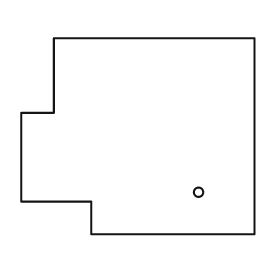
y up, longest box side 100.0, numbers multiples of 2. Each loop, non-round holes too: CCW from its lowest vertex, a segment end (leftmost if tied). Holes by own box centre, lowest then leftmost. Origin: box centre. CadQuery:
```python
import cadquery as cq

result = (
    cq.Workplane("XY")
    .moveTo(-20.0, -42.0)
    .lineTo(50.0, -42.0)
    .lineTo(50.0, 42.0)
    .lineTo(-36.0, 42.0)
    .lineTo(-36.0, 10.0)
    .lineTo(-50.0, 10.0)
    .lineTo(-50.0, -28.0)
    .lineTo(-20.0, -28.0)
    .close()
    .moveTo(26.0, -24.0)
    .circle(2.0)
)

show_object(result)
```